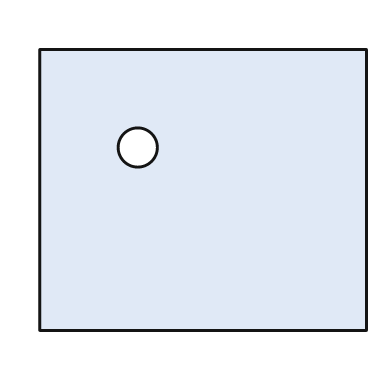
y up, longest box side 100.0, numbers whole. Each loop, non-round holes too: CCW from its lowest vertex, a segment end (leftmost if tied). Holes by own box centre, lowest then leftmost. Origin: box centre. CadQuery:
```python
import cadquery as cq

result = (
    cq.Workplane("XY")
    .moveTo(-50.0, -43.0)
    .lineTo(50.0, -43.0)
    .lineTo(50.0, 43.0)
    .lineTo(-50.0, 43.0)
    .close()
    .moveTo(-20.0, 13.0)
    .circle(6.0)
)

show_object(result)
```